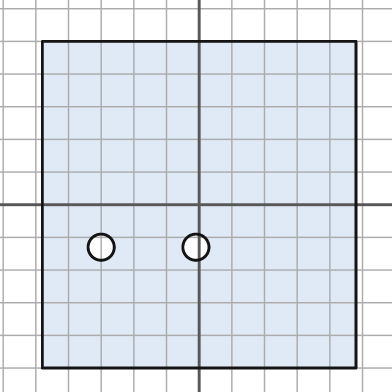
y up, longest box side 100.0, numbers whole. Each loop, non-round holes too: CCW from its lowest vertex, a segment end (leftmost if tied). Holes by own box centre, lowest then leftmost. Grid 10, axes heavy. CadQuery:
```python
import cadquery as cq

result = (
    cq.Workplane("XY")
    .moveTo(-48.0, -50.0)
    .lineTo(48.0, -50.0)
    .lineTo(48.0, 50.0)
    .lineTo(-48.0, 50.0)
    .close()
    .moveTo(-30.0, -13.0)
    .circle(4.0)
    .moveTo(-1.0, -13.0)
    .circle(4.0)
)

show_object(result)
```